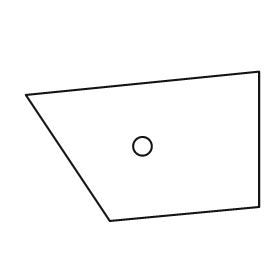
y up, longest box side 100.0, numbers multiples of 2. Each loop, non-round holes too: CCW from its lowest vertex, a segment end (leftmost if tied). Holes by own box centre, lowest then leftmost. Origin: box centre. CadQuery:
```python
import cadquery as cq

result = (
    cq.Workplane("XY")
    .moveTo(-14.0, -32.0)
    .lineTo(50.0, -26.0)
    .lineTo(50.0, 32.0)
    .lineTo(-50.0, 22.0)
    .close()
    .moveTo(0.0, 0.0)
    .circle(4.0)
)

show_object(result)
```